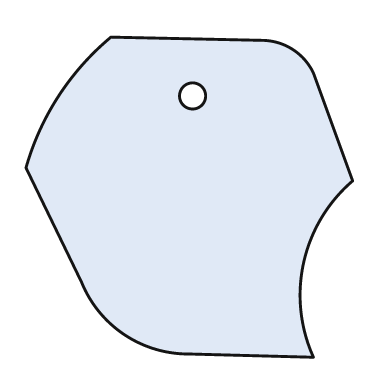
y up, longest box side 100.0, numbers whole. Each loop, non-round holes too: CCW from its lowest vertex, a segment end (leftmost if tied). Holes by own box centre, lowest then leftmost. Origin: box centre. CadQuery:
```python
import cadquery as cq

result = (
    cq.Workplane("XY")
    .moveTo(38.0, -49.0)
    .threePointArc((35.0, -20.0), (50.0, 5.0))
    .lineTo(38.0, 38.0)
    .threePointArc((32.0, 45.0), (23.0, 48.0))
    .lineTo(-24.0, 49.0)
    .threePointArc((-40.0, 31.0), (-50.0, 9.0))
    .lineTo(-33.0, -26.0)
    .threePointArc((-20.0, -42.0), (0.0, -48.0))
    .close()
    .moveTo(1.0, 31.0)
    .circle(4.0)
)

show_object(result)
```